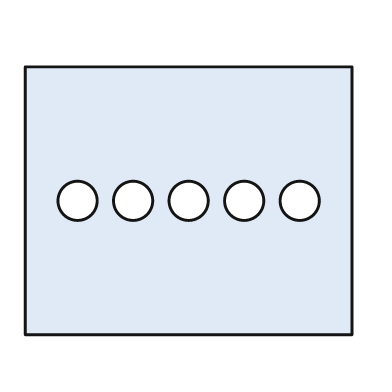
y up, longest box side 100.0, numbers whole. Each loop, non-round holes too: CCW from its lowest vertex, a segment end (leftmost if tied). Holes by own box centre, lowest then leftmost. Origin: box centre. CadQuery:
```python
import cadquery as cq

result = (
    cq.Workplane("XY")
    .moveTo(-50.0, -41.0)
    .lineTo(50.0, -41.0)
    .lineTo(50.0, 41.0)
    .lineTo(-50.0, 41.0)
    .close()
    .moveTo(-34.0, 0.0)
    .circle(6.0)
    .moveTo(-17.0, 0.0)
    .circle(6.0)
    .moveTo(0.0, 0.0)
    .circle(6.0)
    .moveTo(17.0, 0.0)
    .circle(6.0)
    .moveTo(34.0, 0.0)
    .circle(6.0)
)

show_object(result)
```